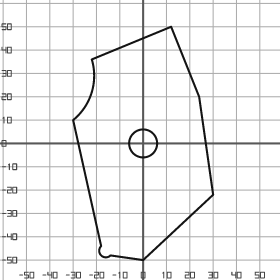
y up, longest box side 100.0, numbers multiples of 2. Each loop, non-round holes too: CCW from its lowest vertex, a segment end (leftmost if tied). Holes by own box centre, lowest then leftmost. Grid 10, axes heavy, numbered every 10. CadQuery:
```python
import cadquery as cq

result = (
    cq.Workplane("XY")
    .moveTo(0.0, -50.0)
    .lineTo(30.0, -22.0)
    .lineTo(24.0, 20.0)
    .lineTo(12.0, 50.0)
    .lineTo(-22.0, 36.0)
    .threePointArc((-22.0, 22.0), (-30.0, 10.0))
    .lineTo(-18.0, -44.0)
    .threePointArc((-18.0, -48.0), (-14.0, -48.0))
    .close()
    .moveTo(0.0, 0.0)
    .circle(6.0)
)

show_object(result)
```